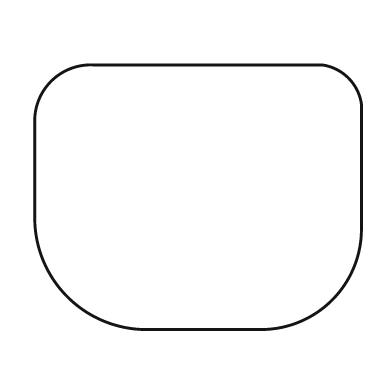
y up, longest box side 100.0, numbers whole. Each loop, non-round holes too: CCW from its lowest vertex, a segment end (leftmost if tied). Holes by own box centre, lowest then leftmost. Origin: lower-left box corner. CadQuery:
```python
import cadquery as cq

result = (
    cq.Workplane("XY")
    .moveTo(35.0, 0.0)
    .lineTo(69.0, 0.0)
    .threePointArc((91.0, 9.0), (100.0, 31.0))
    .lineTo(100.0, 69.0)
    .threePointArc((96.0, 77.0), (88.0, 81.0))
    .lineTo(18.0, 81.0)
    .threePointArc((5.0, 76.0), (0.0, 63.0))
    .lineTo(0.0, 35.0)
    .threePointArc((10.0, 10.0), (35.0, 0.0))
    .close()
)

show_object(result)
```